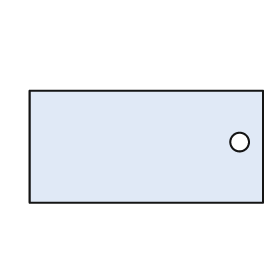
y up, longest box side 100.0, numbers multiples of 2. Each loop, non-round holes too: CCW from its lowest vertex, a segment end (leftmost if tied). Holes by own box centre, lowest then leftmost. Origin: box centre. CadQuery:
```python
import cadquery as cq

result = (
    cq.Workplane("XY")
    .moveTo(-50.0, -24.0)
    .lineTo(50.0, -24.0)
    .lineTo(50.0, 24.0)
    .lineTo(-50.0, 24.0)
    .close()
    .moveTo(40.0, 2.0)
    .circle(4.0)
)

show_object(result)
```